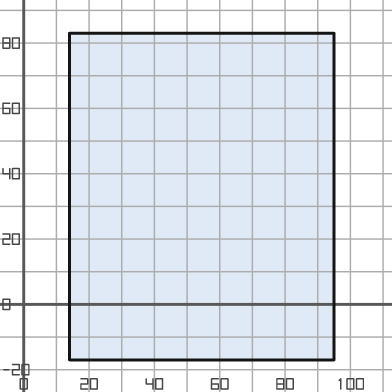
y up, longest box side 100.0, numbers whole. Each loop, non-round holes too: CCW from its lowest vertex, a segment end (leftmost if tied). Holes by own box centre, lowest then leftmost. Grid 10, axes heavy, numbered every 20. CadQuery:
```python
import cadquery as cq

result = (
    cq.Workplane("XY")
    .moveTo(14.0, -17.0)
    .lineTo(95.0, -17.0)
    .lineTo(95.0, 83.0)
    .lineTo(14.0, 83.0)
    .close()
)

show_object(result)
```